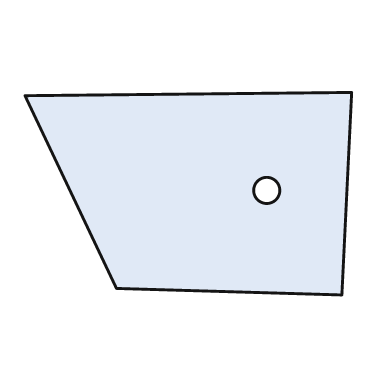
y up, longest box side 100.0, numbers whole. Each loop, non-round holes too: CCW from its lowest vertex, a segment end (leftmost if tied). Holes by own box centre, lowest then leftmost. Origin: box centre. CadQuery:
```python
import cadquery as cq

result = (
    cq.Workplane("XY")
    .moveTo(47.0, -31.0)
    .lineTo(50.0, 31.0)
    .lineTo(-50.0, 30.0)
    .lineTo(-22.0, -29.0)
    .close()
    .moveTo(24.0, 1.0)
    .circle(4.0)
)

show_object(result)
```